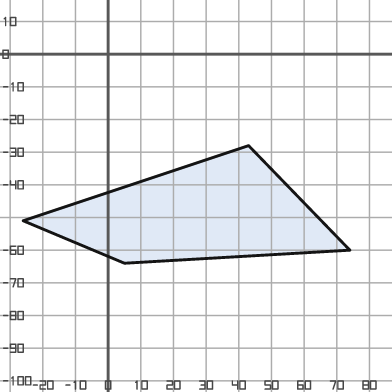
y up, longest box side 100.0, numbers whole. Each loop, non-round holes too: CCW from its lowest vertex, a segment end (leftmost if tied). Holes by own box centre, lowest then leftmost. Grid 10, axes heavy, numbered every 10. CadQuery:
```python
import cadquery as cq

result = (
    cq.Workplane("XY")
    .moveTo(5.0, -64.0)
    .lineTo(74.0, -60.0)
    .lineTo(43.0, -28.0)
    .lineTo(-26.0, -51.0)
    .close()
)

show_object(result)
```